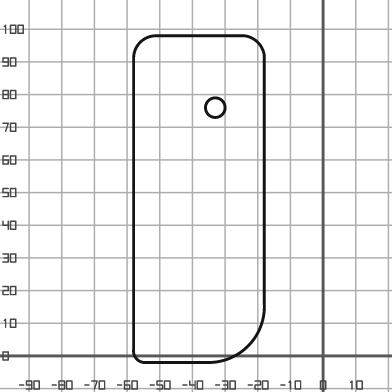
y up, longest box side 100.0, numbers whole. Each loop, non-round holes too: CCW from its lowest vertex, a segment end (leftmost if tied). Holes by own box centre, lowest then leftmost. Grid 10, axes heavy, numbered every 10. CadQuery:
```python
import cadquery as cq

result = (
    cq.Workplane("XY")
    .moveTo(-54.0, -2.0)
    .lineTo(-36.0, -2.0)
    .threePointArc((-23.0, 3.0), (-18.0, 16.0))
    .lineTo(-18.0, 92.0)
    .threePointArc((-20.0, 96.0), (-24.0, 98.0))
    .lineTo(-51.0, 98.0)
    .threePointArc((-56.0, 96.0), (-58.0, 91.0))
    .lineTo(-58.0, 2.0)
    .threePointArc((-57.0, -1.0), (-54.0, -2.0))
    .close()
    .moveTo(-33.0, 76.0)
    .circle(3.0)
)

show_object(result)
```